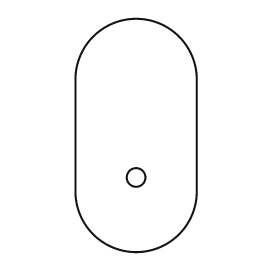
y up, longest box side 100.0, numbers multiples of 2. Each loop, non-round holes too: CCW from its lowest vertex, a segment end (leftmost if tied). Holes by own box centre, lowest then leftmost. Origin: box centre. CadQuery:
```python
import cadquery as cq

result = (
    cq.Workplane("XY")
    .moveTo(-26.0, -24.0)
    .threePointArc((0.0, -50.0), (26.0, -24.0))
    .lineTo(26.0, 24.0)
    .threePointArc((0.0, 50.0), (-26.0, 24.0))
    .close()
    .moveTo(0.0, -18.0)
    .circle(4.0)
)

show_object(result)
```